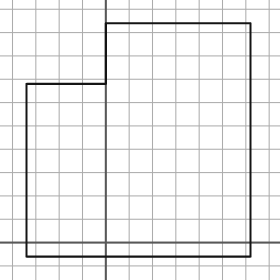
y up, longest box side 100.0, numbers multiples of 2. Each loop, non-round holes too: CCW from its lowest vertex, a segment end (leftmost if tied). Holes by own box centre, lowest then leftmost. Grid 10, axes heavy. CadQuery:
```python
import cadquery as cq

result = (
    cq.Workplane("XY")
    .moveTo(-34.0, -6.0)
    .lineTo(62.0, -6.0)
    .lineTo(62.0, 94.0)
    .lineTo(0.0, 94.0)
    .lineTo(0.0, 68.0)
    .lineTo(-34.0, 68.0)
    .close()
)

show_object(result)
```